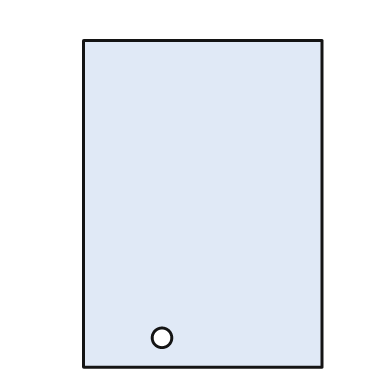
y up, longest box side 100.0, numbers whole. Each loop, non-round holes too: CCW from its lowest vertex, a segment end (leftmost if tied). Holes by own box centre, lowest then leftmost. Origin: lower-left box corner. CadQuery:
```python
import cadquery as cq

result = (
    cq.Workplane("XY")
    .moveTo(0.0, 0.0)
    .lineTo(73.0, 0.0)
    .lineTo(73.0, 100.0)
    .lineTo(0.0, 100.0)
    .close()
    .moveTo(24.0, 9.0)
    .circle(3.0)
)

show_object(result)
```